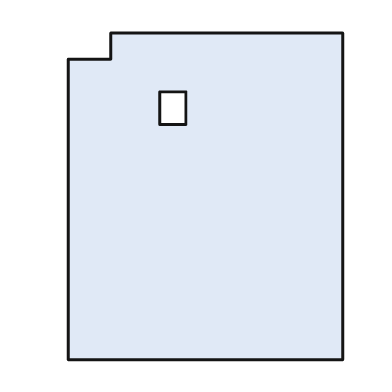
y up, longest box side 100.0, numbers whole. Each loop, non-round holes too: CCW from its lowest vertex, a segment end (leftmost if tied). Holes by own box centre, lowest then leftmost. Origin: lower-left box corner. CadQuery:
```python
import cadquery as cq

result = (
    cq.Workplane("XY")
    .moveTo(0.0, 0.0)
    .lineTo(84.0, 0.0)
    .lineTo(84.0, 100.0)
    .lineTo(13.0, 100.0)
    .lineTo(13.0, 92.0)
    .lineTo(0.0, 92.0)
    .close()
    .moveTo(28.0, 72.0)
    .lineTo(36.0, 72.0)
    .lineTo(36.0, 82.0)
    .lineTo(28.0, 82.0)
    .close()
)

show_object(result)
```